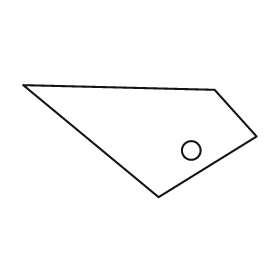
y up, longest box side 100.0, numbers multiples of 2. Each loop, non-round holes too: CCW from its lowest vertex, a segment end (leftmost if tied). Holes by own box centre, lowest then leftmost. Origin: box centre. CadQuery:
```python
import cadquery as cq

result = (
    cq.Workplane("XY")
    .moveTo(8.0, -24.0)
    .lineTo(50.0, 2.0)
    .lineTo(32.0, 22.0)
    .lineTo(-50.0, 24.0)
    .close()
    .moveTo(22.0, -4.0)
    .circle(4.0)
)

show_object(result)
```